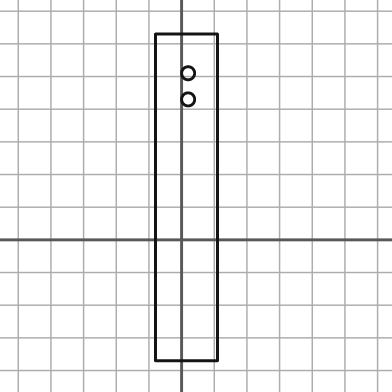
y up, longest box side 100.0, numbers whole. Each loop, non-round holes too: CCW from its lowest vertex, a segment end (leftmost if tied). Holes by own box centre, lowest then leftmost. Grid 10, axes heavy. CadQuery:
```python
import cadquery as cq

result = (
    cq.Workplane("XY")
    .moveTo(-8.0, -37.0)
    .lineTo(11.0, -37.0)
    .lineTo(11.0, 63.0)
    .lineTo(-8.0, 63.0)
    .close()
    .moveTo(2.0, 43.0)
    .circle(2.0)
    .moveTo(2.0, 51.0)
    .circle(2.0)
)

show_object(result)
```